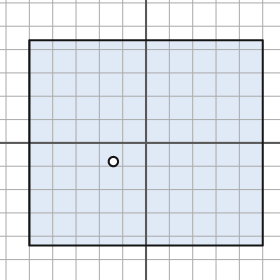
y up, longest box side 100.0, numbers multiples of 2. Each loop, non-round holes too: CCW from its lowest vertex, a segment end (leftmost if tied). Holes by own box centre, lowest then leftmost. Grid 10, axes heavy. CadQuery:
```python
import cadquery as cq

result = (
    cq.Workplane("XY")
    .moveTo(-50.0, -44.0)
    .lineTo(50.0, -44.0)
    .lineTo(50.0, 44.0)
    .lineTo(-50.0, 44.0)
    .close()
    .moveTo(-14.0, -8.0)
    .circle(2.0)
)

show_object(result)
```